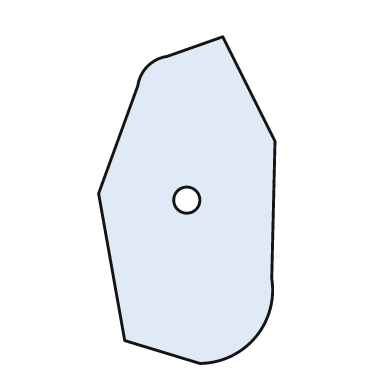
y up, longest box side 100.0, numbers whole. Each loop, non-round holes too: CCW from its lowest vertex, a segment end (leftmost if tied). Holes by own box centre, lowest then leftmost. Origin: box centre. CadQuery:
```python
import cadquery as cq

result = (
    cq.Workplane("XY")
    .moveTo(4.0, -50.0)
    .threePointArc((21.0, -42.0), (26.0, -24.0))
    .lineTo(27.0, 18.0)
    .lineTo(11.0, 50.0)
    .lineTo(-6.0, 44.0)
    .threePointArc((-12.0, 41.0), (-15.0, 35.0))
    .lineTo(-27.0, 2.0)
    .lineTo(-19.0, -43.0)
    .close()
    .moveTo(0.0, 0.0)
    .circle(4.0)
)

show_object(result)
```